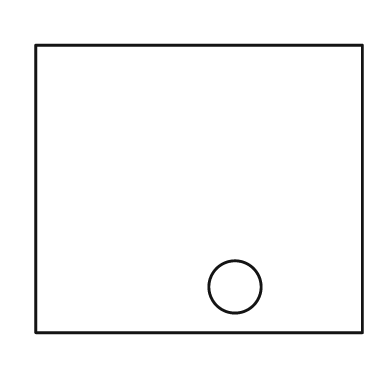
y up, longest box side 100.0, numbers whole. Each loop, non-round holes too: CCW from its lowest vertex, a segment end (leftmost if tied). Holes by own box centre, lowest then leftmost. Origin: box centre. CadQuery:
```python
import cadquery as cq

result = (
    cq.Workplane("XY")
    .moveTo(-50.0, -44.0)
    .lineTo(50.0, -44.0)
    .lineTo(50.0, 44.0)
    .lineTo(-50.0, 44.0)
    .close()
    .moveTo(11.0, -30.0)
    .circle(8.0)
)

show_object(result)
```